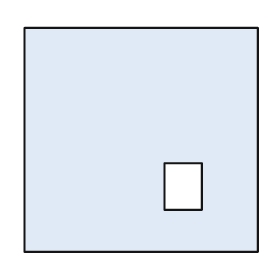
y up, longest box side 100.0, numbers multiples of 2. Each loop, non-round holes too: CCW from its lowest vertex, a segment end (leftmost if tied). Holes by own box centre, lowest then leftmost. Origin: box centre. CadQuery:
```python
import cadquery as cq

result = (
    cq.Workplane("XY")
    .moveTo(-50.0, -48.0)
    .lineTo(50.0, -48.0)
    .lineTo(50.0, 48.0)
    .lineTo(-50.0, 48.0)
    .close()
    .moveTo(10.0, -30.0)
    .lineTo(26.0, -30.0)
    .lineTo(26.0, -10.0)
    .lineTo(10.0, -10.0)
    .close()
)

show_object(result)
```